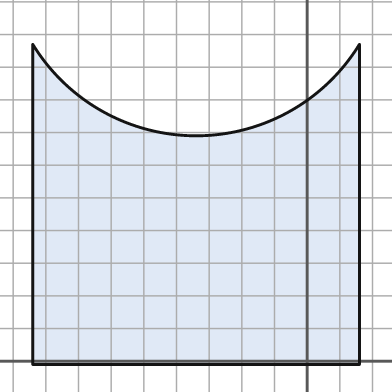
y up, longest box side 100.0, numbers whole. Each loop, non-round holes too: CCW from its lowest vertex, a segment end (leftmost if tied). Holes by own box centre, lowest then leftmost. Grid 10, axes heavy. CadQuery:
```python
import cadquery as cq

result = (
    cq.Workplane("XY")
    .moveTo(-84.0, -1.0)
    .lineTo(16.0, -1.0)
    .lineTo(16.0, 97.0)
    .threePointArc((-34.0, 69.0), (-84.0, 97.0))
    .close()
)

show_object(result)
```